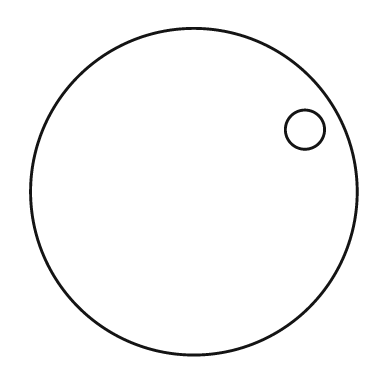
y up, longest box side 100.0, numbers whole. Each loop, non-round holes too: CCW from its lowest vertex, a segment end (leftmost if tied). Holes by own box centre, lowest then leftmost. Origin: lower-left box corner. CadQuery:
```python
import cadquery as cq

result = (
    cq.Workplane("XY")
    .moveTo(50.0, 50.0)
    .circle(50.0)
    .moveTo(84.0, 69.0)
    .circle(6.0)
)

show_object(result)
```